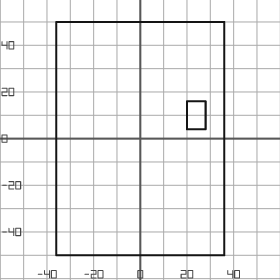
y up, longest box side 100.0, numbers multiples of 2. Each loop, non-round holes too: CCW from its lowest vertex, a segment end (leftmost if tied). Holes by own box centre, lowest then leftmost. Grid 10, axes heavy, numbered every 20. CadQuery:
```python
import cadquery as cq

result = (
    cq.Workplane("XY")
    .moveTo(-36.0, -50.0)
    .lineTo(36.0, -50.0)
    .lineTo(36.0, 50.0)
    .lineTo(-36.0, 50.0)
    .close()
    .moveTo(20.0, 4.0)
    .lineTo(28.0, 4.0)
    .lineTo(28.0, 16.0)
    .lineTo(20.0, 16.0)
    .close()
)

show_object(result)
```